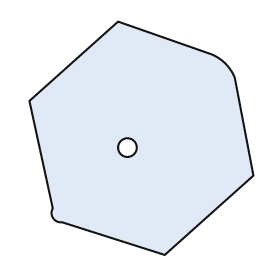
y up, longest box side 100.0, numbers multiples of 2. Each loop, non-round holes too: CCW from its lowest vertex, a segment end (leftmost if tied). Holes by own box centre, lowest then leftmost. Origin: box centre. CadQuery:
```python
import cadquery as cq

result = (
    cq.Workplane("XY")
    .moveTo(10.0, -50.0)
    .lineTo(48.0, -16.0)
    .lineTo(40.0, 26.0)
    .threePointArc((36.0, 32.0), (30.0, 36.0))
    .lineTo(-10.0, 50.0)
    .lineTo(-48.0, 16.0)
    .lineTo(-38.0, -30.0)
    .threePointArc((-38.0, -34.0), (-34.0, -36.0))
    .close()
    .moveTo(-6.0, -4.0)
    .circle(4.0)
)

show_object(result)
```